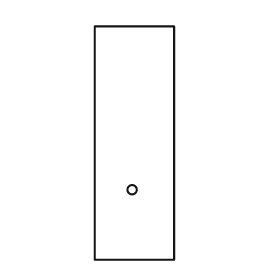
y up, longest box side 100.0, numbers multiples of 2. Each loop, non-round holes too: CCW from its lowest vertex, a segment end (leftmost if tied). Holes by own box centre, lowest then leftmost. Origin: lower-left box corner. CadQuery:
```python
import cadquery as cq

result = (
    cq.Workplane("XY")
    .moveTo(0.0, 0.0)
    .lineTo(34.0, 0.0)
    .lineTo(34.0, 100.0)
    .lineTo(0.0, 100.0)
    .close()
    .moveTo(16.0, 30.0)
    .circle(2.0)
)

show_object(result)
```